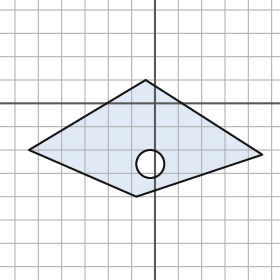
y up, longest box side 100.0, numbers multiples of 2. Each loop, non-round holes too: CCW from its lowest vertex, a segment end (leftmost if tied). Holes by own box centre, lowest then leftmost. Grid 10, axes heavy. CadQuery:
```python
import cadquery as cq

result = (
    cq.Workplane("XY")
    .moveTo(-8.0, -40.0)
    .lineTo(46.0, -22.0)
    .lineTo(-4.0, 10.0)
    .lineTo(-54.0, -20.0)
    .close()
    .moveTo(-2.0, -26.0)
    .circle(6.0)
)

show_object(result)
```